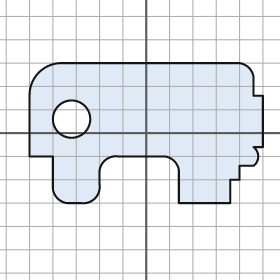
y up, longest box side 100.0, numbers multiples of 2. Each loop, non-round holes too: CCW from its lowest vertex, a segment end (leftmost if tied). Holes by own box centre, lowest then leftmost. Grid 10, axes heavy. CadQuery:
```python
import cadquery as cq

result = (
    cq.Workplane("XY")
    .moveTo(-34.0, -30.0)
    .lineTo(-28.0, -30.0)
    .threePointArc((-22.0, -28.0), (-20.0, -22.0))
    .lineTo(-20.0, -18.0)
    .threePointArc((-18.0, -12.0), (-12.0, -10.0))
    .lineTo(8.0, -10.0)
    .threePointArc((12.0, -12.0), (14.0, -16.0))
    .lineTo(14.0, -30.0)
    .lineTo(36.0, -30.0)
    .lineTo(36.0, -20.0)
    .lineTo(40.0, -20.0)
    .lineTo(40.0, -14.0)
    .lineTo(46.0, -14.0)
    .threePointArc((48.0, -10.0), (46.0, -6.0))
    .lineTo(50.0, -6.0)
    .lineTo(50.0, 16.0)
    .lineTo(46.0, 16.0)
    .lineTo(46.0, 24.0)
    .threePointArc((44.0, 28.0), (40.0, 30.0))
    .lineTo(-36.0, 30.0)
    .threePointArc((-46.0, 26.0), (-50.0, 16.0))
    .lineTo(-50.0, -10.0)
    .lineTo(-40.0, -10.0)
    .lineTo(-40.0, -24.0)
    .threePointArc((-38.0, -28.0), (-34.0, -30.0))
    .close()
    .moveTo(-32.0, 6.0)
    .circle(8.0)
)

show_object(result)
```